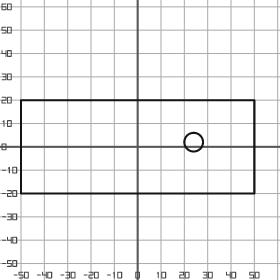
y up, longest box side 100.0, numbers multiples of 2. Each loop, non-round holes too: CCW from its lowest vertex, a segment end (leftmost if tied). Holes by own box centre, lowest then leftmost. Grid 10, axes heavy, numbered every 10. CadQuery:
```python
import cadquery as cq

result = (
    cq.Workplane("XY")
    .moveTo(-50.0, -20.0)
    .lineTo(50.0, -20.0)
    .lineTo(50.0, 20.0)
    .lineTo(-50.0, 20.0)
    .close()
    .moveTo(24.0, 2.0)
    .circle(4.0)
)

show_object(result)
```